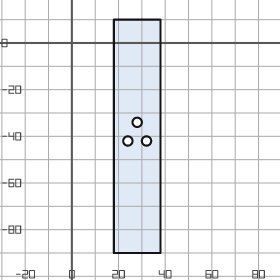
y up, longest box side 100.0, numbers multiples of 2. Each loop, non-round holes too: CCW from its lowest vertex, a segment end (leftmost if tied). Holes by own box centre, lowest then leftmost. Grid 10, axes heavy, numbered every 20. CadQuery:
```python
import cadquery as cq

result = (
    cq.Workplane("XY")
    .moveTo(18.0, -90.0)
    .lineTo(38.0, -90.0)
    .lineTo(38.0, 10.0)
    .lineTo(18.0, 10.0)
    .close()
    .moveTo(24.0, -42.0)
    .circle(2.0)
    .moveTo(32.0, -42.0)
    .circle(2.0)
    .moveTo(28.0, -34.0)
    .circle(2.0)
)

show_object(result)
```